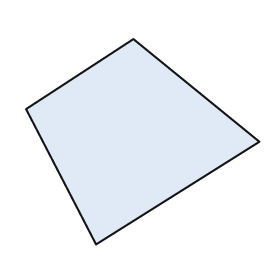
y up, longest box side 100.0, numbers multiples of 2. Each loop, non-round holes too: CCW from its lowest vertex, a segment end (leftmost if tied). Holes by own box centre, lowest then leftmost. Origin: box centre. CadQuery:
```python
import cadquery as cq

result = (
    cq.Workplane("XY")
    .moveTo(-20.0, -44.0)
    .lineTo(50.0, 0.0)
    .lineTo(-4.0, 44.0)
    .lineTo(-50.0, 14.0)
    .close()
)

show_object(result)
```